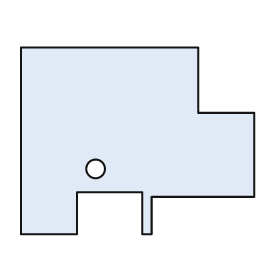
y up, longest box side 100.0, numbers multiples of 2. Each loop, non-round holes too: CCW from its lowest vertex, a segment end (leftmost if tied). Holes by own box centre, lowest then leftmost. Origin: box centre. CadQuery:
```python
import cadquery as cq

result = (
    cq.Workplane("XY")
    .moveTo(-50.0, -40.0)
    .lineTo(-26.0, -40.0)
    .lineTo(-26.0, -22.0)
    .lineTo(2.0, -22.0)
    .lineTo(2.0, -40.0)
    .lineTo(6.0, -40.0)
    .lineTo(6.0, -24.0)
    .lineTo(50.0, -24.0)
    .lineTo(50.0, 12.0)
    .lineTo(26.0, 12.0)
    .lineTo(26.0, 40.0)
    .lineTo(-50.0, 40.0)
    .close()
    .moveTo(-18.0, -12.0)
    .circle(4.0)
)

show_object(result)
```